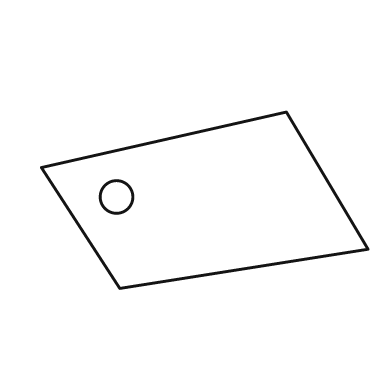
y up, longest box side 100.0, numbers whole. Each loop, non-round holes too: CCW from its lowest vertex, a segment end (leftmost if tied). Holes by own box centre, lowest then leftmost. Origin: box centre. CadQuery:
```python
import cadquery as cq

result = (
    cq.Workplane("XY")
    .moveTo(-26.0, -27.0)
    .lineTo(50.0, -15.0)
    .lineTo(25.0, 27.0)
    .lineTo(-50.0, 10.0)
    .close()
    .moveTo(-27.0, 1.0)
    .circle(5.0)
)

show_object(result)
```